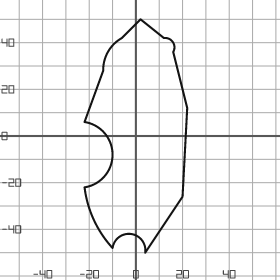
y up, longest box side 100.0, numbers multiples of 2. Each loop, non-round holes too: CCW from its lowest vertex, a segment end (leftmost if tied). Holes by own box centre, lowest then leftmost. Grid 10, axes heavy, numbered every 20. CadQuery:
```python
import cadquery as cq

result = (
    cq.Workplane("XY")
    .moveTo(4.0, -50.0)
    .lineTo(20.0, -26.0)
    .lineTo(22.0, 12.0)
    .lineTo(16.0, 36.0)
    .threePointArc((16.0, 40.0), (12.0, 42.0))
    .lineTo(2.0, 50.0)
    .lineTo(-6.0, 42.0)
    .threePointArc((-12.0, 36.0), (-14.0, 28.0))
    .lineTo(-22.0, 6.0)
    .threePointArc((-10.0, -8.0), (-22.0, -22.0))
    .threePointArc((-18.0, -36.0), (-10.0, -48.0))
    .threePointArc((-2.0, -42.0), (4.0, -50.0))
    .close()
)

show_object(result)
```